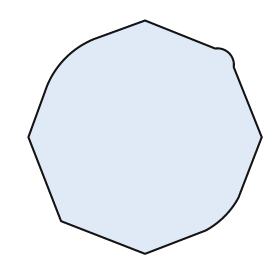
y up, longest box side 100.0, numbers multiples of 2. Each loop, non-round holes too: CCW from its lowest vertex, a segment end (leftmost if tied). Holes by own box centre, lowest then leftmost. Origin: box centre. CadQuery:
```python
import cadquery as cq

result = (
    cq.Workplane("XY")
    .moveTo(0.0, -50.0)
    .lineTo(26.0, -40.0)
    .threePointArc((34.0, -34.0), (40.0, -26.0))
    .lineTo(50.0, 0.0)
    .lineTo(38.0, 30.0)
    .threePointArc((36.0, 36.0), (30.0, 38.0))
    .lineTo(0.0, 50.0)
    .lineTo(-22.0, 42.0)
    .threePointArc((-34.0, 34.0), (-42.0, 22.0))
    .lineTo(-50.0, 0.0)
    .lineTo(-36.0, -36.0)
    .close()
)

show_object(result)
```